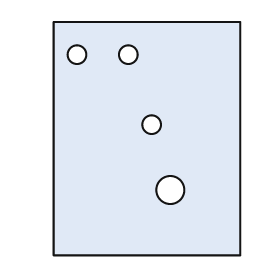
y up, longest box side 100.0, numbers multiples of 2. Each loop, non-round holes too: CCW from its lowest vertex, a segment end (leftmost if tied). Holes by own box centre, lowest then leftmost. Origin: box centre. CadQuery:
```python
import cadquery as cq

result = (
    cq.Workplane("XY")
    .moveTo(-40.0, -50.0)
    .lineTo(40.0, -50.0)
    .lineTo(40.0, 50.0)
    .lineTo(-40.0, 50.0)
    .close()
    .moveTo(10.0, -22.0)
    .circle(6.0)
    .moveTo(2.0, 6.0)
    .circle(4.0)
    .moveTo(-30.0, 36.0)
    .circle(4.0)
    .moveTo(-8.0, 36.0)
    .circle(4.0)
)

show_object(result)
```